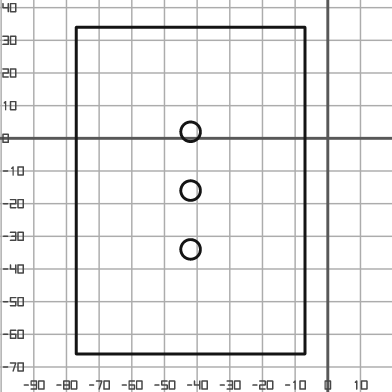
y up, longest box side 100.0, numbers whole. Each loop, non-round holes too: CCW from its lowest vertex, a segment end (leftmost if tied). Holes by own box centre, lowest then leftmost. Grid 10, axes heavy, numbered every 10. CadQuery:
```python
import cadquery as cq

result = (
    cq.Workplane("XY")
    .moveTo(-77.0, -66.0)
    .lineTo(-7.0, -66.0)
    .lineTo(-7.0, 34.0)
    .lineTo(-77.0, 34.0)
    .close()
    .moveTo(-42.0, -34.0)
    .circle(3.0)
    .moveTo(-42.0, -16.0)
    .circle(3.0)
    .moveTo(-42.0, 2.0)
    .circle(3.0)
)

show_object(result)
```